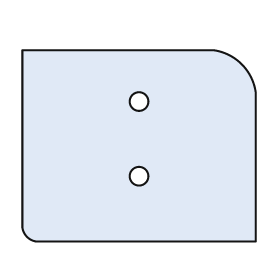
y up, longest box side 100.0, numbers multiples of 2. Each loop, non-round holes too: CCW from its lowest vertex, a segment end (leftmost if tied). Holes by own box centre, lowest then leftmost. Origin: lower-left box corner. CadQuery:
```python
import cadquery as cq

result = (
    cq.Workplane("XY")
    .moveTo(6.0, 0.0)
    .lineTo(100.0, 0.0)
    .lineTo(100.0, 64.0)
    .threePointArc((94.0, 76.0), (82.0, 82.0))
    .lineTo(0.0, 82.0)
    .lineTo(0.0, 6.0)
    .threePointArc((2.0, 2.0), (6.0, 0.0))
    .close()
    .moveTo(50.0, 28.0)
    .circle(4.0)
    .moveTo(50.0, 60.0)
    .circle(4.0)
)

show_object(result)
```